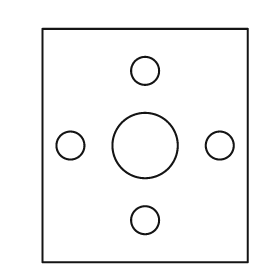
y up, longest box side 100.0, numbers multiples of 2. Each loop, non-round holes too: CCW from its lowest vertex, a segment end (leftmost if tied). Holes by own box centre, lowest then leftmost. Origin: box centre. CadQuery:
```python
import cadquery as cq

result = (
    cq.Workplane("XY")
    .moveTo(-44.0, -50.0)
    .lineTo(44.0, -50.0)
    .lineTo(44.0, 50.0)
    .lineTo(-44.0, 50.0)
    .close()
    .moveTo(0.0, -32.0)
    .circle(6.0)
    .moveTo(-32.0, 0.0)
    .circle(6.0)
    .moveTo(0.0, 0.0)
    .circle(14.0)
    .moveTo(32.0, 0.0)
    .circle(6.0)
    .moveTo(0.0, 32.0)
    .circle(6.0)
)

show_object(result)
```